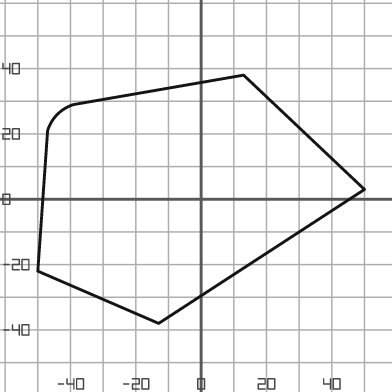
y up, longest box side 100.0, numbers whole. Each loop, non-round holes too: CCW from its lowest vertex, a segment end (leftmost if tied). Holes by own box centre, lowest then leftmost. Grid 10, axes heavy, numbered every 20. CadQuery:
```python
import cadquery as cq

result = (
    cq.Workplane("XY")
    .moveTo(-13.0, -38.0)
    .lineTo(50.0, 3.0)
    .lineTo(13.0, 38.0)
    .lineTo(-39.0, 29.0)
    .threePointArc((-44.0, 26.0), (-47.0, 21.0))
    .lineTo(-50.0, -22.0)
    .close()
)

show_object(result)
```